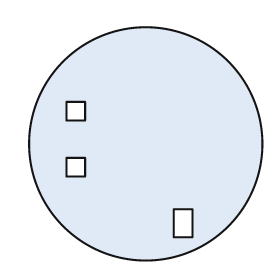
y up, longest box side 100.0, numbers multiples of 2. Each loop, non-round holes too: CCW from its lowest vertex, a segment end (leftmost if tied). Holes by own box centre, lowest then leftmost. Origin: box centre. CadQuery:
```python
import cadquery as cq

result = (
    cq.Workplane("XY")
    .moveTo(0.0, 0.0)
    .circle(50.0)
    .moveTo(12.0, -40.0)
    .lineTo(20.0, -40.0)
    .lineTo(20.0, -28.0)
    .lineTo(12.0, -28.0)
    .close()
    .moveTo(-34.0, -14.0)
    .lineTo(-26.0, -14.0)
    .lineTo(-26.0, -6.0)
    .lineTo(-34.0, -6.0)
    .close()
    .moveTo(-34.0, 10.0)
    .lineTo(-26.0, 10.0)
    .lineTo(-26.0, 18.0)
    .lineTo(-34.0, 18.0)
    .close()
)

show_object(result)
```